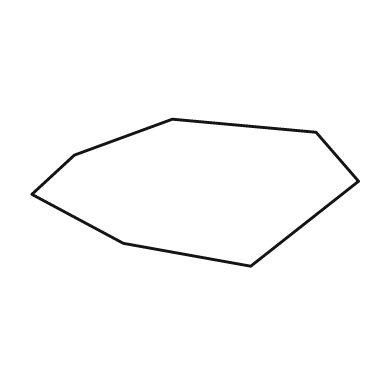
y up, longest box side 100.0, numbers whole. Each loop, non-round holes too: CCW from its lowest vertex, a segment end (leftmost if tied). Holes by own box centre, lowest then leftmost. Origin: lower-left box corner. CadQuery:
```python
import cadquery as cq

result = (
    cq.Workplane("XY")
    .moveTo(67.0, 0.0)
    .lineTo(100.0, 26.0)
    .lineTo(87.0, 41.0)
    .lineTo(43.0, 45.0)
    .lineTo(13.0, 34.0)
    .lineTo(0.0, 22.0)
    .lineTo(28.0, 7.0)
    .close()
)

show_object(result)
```